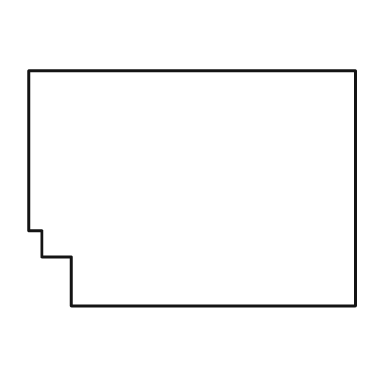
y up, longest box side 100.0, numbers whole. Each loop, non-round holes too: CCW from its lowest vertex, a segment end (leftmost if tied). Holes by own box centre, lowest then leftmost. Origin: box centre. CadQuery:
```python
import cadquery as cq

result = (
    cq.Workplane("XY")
    .moveTo(-37.0, -36.0)
    .lineTo(50.0, -36.0)
    .lineTo(50.0, 36.0)
    .lineTo(-50.0, 36.0)
    .lineTo(-50.0, -13.0)
    .lineTo(-46.0, -13.0)
    .lineTo(-46.0, -21.0)
    .lineTo(-37.0, -21.0)
    .close()
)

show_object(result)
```